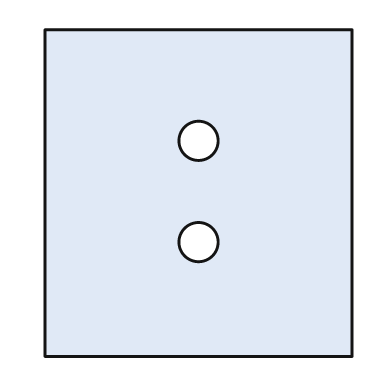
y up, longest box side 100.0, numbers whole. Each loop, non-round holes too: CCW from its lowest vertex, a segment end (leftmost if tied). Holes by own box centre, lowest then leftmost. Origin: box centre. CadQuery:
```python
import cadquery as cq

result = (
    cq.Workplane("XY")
    .moveTo(-47.0, -50.0)
    .lineTo(47.0, -50.0)
    .lineTo(47.0, 50.0)
    .lineTo(-47.0, 50.0)
    .close()
    .moveTo(0.0, -15.0)
    .circle(6.0)
    .moveTo(0.0, 16.0)
    .circle(6.0)
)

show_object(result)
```